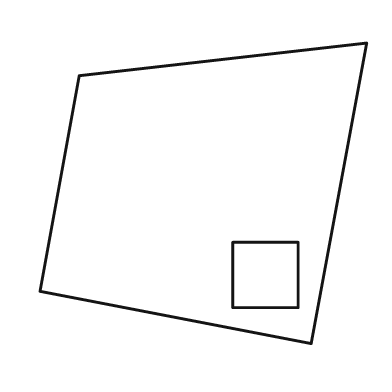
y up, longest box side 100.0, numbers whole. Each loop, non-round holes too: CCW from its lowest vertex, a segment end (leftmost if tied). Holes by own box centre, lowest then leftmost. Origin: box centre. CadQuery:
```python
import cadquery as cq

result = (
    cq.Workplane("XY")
    .moveTo(33.0, -46.0)
    .lineTo(50.0, 46.0)
    .lineTo(-38.0, 36.0)
    .lineTo(-50.0, -30.0)
    .close()
    .moveTo(9.0, -35.0)
    .lineTo(29.0, -35.0)
    .lineTo(29.0, -15.0)
    .lineTo(9.0, -15.0)
    .close()
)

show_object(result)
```